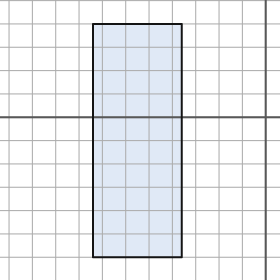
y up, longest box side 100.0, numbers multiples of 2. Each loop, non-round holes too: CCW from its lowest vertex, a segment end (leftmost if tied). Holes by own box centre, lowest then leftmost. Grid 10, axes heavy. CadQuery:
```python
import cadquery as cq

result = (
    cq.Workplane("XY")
    .moveTo(-74.0, -60.0)
    .lineTo(-36.0, -60.0)
    .lineTo(-36.0, 40.0)
    .lineTo(-74.0, 40.0)
    .close()
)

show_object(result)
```